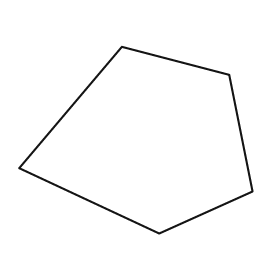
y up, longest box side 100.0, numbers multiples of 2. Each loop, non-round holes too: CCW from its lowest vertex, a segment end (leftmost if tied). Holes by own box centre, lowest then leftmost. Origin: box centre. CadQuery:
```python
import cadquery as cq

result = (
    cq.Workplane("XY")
    .moveTo(10.0, -40.0)
    .lineTo(50.0, -22.0)
    .lineTo(40.0, 28.0)
    .lineTo(-6.0, 40.0)
    .lineTo(-50.0, -12.0)
    .close()
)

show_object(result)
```